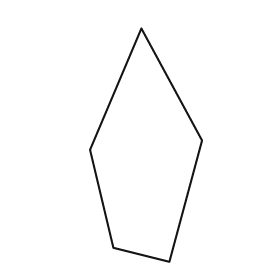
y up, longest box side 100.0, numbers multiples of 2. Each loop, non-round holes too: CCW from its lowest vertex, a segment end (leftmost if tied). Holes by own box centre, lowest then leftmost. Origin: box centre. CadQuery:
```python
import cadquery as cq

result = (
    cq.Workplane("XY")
    .moveTo(10.0, -50.0)
    .lineTo(24.0, 2.0)
    .lineTo(-2.0, 50.0)
    .lineTo(-24.0, -2.0)
    .lineTo(-14.0, -44.0)
    .close()
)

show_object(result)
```